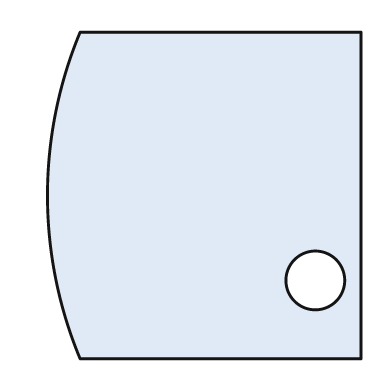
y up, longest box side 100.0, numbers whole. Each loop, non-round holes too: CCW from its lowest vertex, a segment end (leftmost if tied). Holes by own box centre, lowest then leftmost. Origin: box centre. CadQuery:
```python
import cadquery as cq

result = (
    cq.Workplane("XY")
    .moveTo(-38.0, -50.0)
    .lineTo(48.0, -50.0)
    .lineTo(48.0, 50.0)
    .lineTo(-38.0, 50.0)
    .threePointArc((-48.0, 0.0), (-38.0, -50.0))
    .close()
    .moveTo(34.0, -26.0)
    .circle(9.0)
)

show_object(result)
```